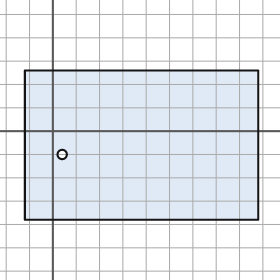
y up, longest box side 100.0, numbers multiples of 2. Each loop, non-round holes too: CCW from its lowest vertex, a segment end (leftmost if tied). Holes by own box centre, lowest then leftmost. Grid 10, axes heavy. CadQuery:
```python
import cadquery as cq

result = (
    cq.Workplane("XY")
    .moveTo(-12.0, -38.0)
    .lineTo(88.0, -38.0)
    .lineTo(88.0, 26.0)
    .lineTo(-12.0, 26.0)
    .close()
    .moveTo(4.0, -10.0)
    .circle(2.0)
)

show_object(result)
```